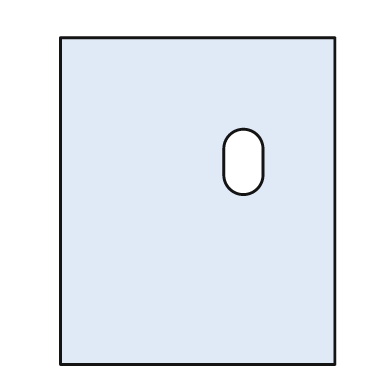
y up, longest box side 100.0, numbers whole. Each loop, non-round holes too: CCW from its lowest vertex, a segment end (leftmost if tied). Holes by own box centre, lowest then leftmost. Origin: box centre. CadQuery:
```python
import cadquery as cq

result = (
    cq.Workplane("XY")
    .moveTo(-42.0, -50.0)
    .lineTo(42.0, -50.0)
    .lineTo(42.0, 50.0)
    .lineTo(-42.0, 50.0)
    .close()
    .moveTo(8.0, 8.0)
    .threePointArc((14.0, 2.0), (20.0, 8.0))
    .lineTo(20.0, 16.0)
    .threePointArc((14.0, 22.0), (8.0, 16.0))
    .close()
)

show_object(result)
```